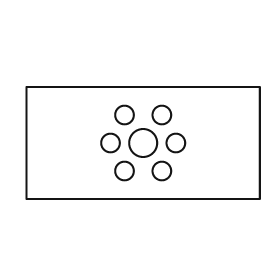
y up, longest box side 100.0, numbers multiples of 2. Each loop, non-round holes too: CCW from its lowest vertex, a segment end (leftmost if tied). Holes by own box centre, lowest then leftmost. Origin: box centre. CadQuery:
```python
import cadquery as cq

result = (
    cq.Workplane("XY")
    .moveTo(-50.0, -24.0)
    .lineTo(50.0, -24.0)
    .lineTo(50.0, 24.0)
    .lineTo(-50.0, 24.0)
    .close()
    .moveTo(-8.0, -12.0)
    .circle(4.0)
    .moveTo(8.0, -12.0)
    .circle(4.0)
    .moveTo(-14.0, 0.0)
    .circle(4.0)
    .moveTo(0.0, 0.0)
    .circle(6.0)
    .moveTo(14.0, 0.0)
    .circle(4.0)
    .moveTo(-8.0, 12.0)
    .circle(4.0)
    .moveTo(8.0, 12.0)
    .circle(4.0)
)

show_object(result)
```